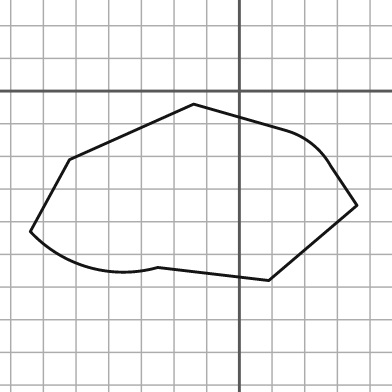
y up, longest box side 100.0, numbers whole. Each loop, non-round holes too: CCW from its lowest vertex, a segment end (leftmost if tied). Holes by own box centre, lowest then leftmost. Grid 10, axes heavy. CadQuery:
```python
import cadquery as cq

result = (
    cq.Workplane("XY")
    .moveTo(9.0, -58.0)
    .lineTo(36.0, -35.0)
    .lineTo(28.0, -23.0)
    .threePointArc((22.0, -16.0), (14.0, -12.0))
    .lineTo(-14.0, -4.0)
    .lineTo(-52.0, -21.0)
    .lineTo(-64.0, -43.0)
    .threePointArc((-46.0, -54.0), (-25.0, -54.0))
    .close()
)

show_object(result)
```